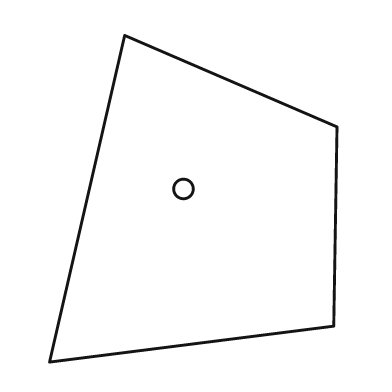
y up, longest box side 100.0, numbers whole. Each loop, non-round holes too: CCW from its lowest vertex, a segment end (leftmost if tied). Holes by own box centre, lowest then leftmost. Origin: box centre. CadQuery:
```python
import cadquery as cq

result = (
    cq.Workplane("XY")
    .moveTo(-44.0, -50.0)
    .lineTo(43.0, -39.0)
    .lineTo(44.0, 22.0)
    .lineTo(-21.0, 50.0)
    .close()
    .moveTo(-3.0, 3.0)
    .circle(3.0)
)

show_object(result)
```